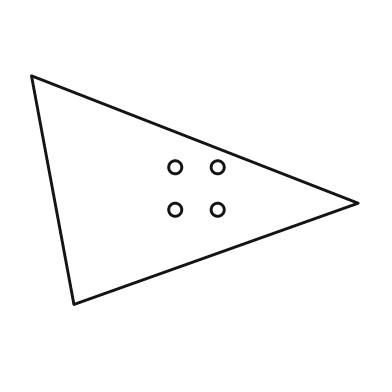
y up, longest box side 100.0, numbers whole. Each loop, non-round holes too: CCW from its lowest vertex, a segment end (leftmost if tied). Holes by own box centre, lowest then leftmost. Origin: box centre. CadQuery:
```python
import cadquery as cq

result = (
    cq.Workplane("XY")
    .moveTo(-37.0, -35.0)
    .lineTo(50.0, -4.0)
    .lineTo(-50.0, 35.0)
    .close()
    .moveTo(-6.0, -6.0)
    .circle(2.0)
    .moveTo(7.0, -6.0)
    .circle(2.0)
    .moveTo(-6.0, 7.0)
    .circle(2.0)
    .moveTo(7.0, 7.0)
    .circle(2.0)
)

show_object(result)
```